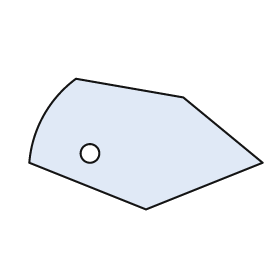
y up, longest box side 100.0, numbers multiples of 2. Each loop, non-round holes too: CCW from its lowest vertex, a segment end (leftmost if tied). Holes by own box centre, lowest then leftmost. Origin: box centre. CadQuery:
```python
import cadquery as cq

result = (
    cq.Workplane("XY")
    .moveTo(0.0, -28.0)
    .lineTo(50.0, -8.0)
    .lineTo(16.0, 20.0)
    .lineTo(-30.0, 28.0)
    .threePointArc((-44.0, 12.0), (-50.0, -8.0))
    .close()
    .moveTo(-24.0, -4.0)
    .circle(4.0)
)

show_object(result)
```